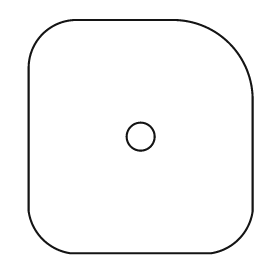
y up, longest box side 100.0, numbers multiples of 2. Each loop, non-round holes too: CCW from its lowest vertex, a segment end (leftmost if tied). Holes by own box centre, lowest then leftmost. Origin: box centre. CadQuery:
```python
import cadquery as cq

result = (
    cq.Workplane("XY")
    .moveTo(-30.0, -50.0)
    .lineTo(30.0, -50.0)
    .threePointArc((42.0, -44.0), (48.0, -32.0))
    .lineTo(48.0, 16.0)
    .threePointArc((38.0, 40.0), (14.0, 50.0))
    .lineTo(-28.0, 50.0)
    .threePointArc((-42.0, 44.0), (-48.0, 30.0))
    .lineTo(-48.0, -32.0)
    .threePointArc((-42.0, -44.0), (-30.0, -50.0))
    .close()
    .moveTo(0.0, 0.0)
    .circle(6.0)
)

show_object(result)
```